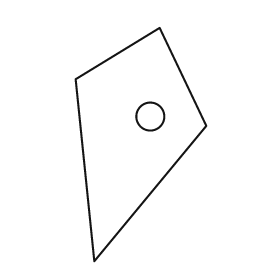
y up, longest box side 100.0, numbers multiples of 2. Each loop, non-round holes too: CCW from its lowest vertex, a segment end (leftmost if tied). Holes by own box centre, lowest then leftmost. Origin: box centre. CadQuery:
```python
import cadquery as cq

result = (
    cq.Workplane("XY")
    .moveTo(-20.0, -50.0)
    .lineTo(28.0, 8.0)
    .lineTo(8.0, 50.0)
    .lineTo(-28.0, 28.0)
    .close()
    .moveTo(4.0, 12.0)
    .circle(6.0)
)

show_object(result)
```